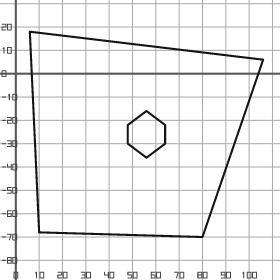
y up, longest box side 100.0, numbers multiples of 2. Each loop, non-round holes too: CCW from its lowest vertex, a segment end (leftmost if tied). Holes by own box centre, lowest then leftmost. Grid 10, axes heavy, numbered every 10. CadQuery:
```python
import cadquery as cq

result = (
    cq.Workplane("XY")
    .moveTo(80.0, -70.0)
    .lineTo(106.0, 6.0)
    .lineTo(6.0, 18.0)
    .lineTo(10.0, -68.0)
    .close()
    .moveTo(56.0, -36.0)
    .lineTo(64.0, -30.0)
    .lineTo(64.0, -22.0)
    .lineTo(56.0, -16.0)
    .lineTo(48.0, -22.0)
    .lineTo(48.0, -30.0)
    .close()
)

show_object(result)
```